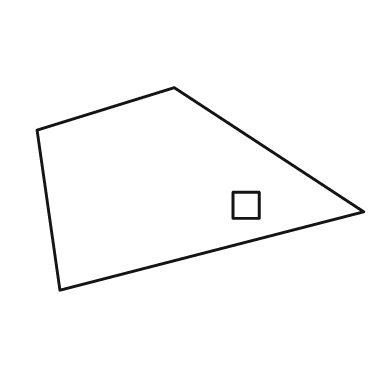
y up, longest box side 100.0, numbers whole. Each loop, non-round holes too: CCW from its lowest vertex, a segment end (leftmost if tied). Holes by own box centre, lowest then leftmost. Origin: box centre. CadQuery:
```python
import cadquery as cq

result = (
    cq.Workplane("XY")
    .moveTo(-43.0, -31.0)
    .lineTo(50.0, -7.0)
    .lineTo(-8.0, 31.0)
    .lineTo(-50.0, 18.0)
    .close()
    .moveTo(10.0, -9.0)
    .lineTo(18.0, -9.0)
    .lineTo(18.0, -1.0)
    .lineTo(10.0, -1.0)
    .close()
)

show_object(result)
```